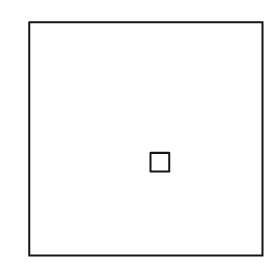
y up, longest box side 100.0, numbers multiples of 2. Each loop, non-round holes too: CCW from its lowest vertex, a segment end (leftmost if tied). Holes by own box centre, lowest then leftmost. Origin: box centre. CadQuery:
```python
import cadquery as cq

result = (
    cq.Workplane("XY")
    .moveTo(-50.0, -50.0)
    .lineTo(50.0, -50.0)
    .lineTo(50.0, 50.0)
    .lineTo(-50.0, 50.0)
    .close()
    .moveTo(2.0, -14.0)
    .lineTo(10.0, -14.0)
    .lineTo(10.0, -6.0)
    .lineTo(2.0, -6.0)
    .close()
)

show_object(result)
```